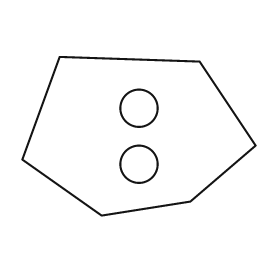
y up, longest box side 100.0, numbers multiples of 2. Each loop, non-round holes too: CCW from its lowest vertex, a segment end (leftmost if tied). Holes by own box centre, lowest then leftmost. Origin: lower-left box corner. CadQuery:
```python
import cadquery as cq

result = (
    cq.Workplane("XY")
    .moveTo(34.0, 0.0)
    .lineTo(72.0, 6.0)
    .lineTo(100.0, 30.0)
    .lineTo(76.0, 66.0)
    .lineTo(16.0, 68.0)
    .lineTo(0.0, 24.0)
    .close()
    .moveTo(50.0, 22.0)
    .circle(8.0)
    .moveTo(50.0, 46.0)
    .circle(8.0)
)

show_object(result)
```